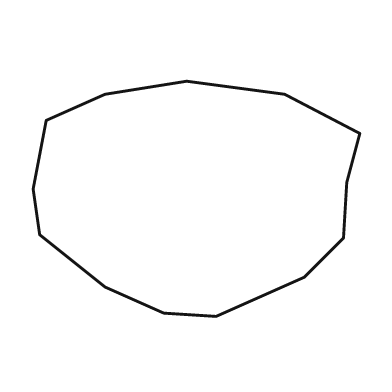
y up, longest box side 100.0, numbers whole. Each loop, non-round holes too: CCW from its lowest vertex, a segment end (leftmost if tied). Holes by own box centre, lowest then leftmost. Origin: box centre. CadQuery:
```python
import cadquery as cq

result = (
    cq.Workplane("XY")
    .moveTo(6.0, -36.0)
    .lineTo(33.0, -24.0)
    .lineTo(45.0, -12.0)
    .lineTo(46.0, 5.0)
    .lineTo(50.0, 20.0)
    .lineTo(27.0, 32.0)
    .lineTo(-3.0, 36.0)
    .lineTo(-28.0, 32.0)
    .lineTo(-46.0, 24.0)
    .lineTo(-50.0, 3.0)
    .lineTo(-48.0, -11.0)
    .lineTo(-28.0, -27.0)
    .lineTo(-10.0, -35.0)
    .close()
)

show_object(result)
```